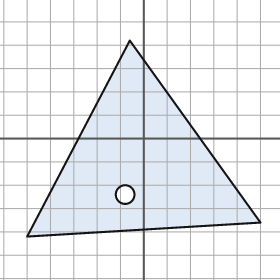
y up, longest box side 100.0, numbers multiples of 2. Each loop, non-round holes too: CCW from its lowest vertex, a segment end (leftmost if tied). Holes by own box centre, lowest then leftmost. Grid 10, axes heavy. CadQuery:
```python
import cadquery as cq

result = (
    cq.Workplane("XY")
    .moveTo(-50.0, -42.0)
    .lineTo(50.0, -36.0)
    .lineTo(-6.0, 42.0)
    .close()
    .moveTo(-8.0, -24.0)
    .circle(4.0)
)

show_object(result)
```